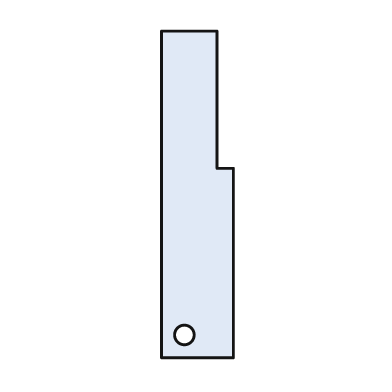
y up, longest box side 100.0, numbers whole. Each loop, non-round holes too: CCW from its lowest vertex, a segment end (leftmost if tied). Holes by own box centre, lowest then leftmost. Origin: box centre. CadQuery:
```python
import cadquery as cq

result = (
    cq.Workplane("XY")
    .moveTo(-11.0, -50.0)
    .lineTo(11.0, -50.0)
    .lineTo(11.0, 8.0)
    .lineTo(6.0, 8.0)
    .lineTo(6.0, 50.0)
    .lineTo(-11.0, 50.0)
    .close()
    .moveTo(-4.0, -43.0)
    .circle(3.0)
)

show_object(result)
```